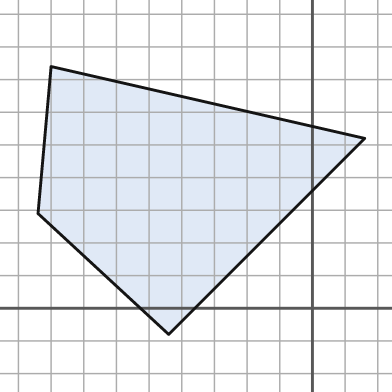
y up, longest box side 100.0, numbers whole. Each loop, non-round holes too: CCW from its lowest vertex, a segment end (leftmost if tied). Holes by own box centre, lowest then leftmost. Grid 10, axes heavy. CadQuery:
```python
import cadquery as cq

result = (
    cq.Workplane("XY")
    .moveTo(-44.0, -8.0)
    .lineTo(16.0, 52.0)
    .lineTo(-80.0, 74.0)
    .lineTo(-84.0, 29.0)
    .close()
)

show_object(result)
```